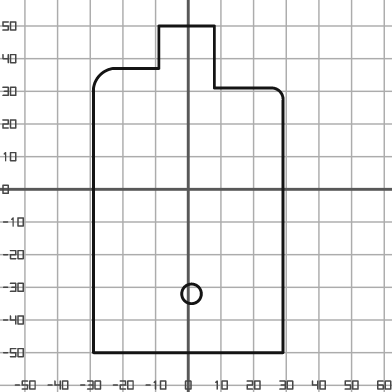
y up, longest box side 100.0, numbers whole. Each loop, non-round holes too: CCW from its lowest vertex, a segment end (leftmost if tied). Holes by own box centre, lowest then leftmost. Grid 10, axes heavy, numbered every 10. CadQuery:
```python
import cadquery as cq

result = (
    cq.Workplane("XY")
    .moveTo(-29.0, -50.0)
    .lineTo(29.0, -50.0)
    .lineTo(29.0, 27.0)
    .threePointArc((28.0, 30.0), (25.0, 31.0))
    .lineTo(8.0, 31.0)
    .lineTo(8.0, 50.0)
    .lineTo(-9.0, 50.0)
    .lineTo(-9.0, 37.0)
    .lineTo(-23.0, 37.0)
    .threePointArc((-27.0, 35.0), (-29.0, 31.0))
    .close()
    .moveTo(1.0, -32.0)
    .circle(3.0)
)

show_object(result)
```